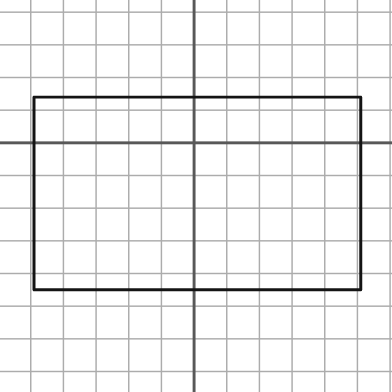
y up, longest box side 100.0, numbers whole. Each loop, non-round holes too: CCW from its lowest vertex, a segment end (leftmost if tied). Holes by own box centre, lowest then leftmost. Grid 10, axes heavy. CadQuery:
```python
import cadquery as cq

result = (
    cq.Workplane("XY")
    .moveTo(-49.0, -45.0)
    .lineTo(51.0, -45.0)
    .lineTo(51.0, 14.0)
    .lineTo(-49.0, 14.0)
    .close()
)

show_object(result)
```